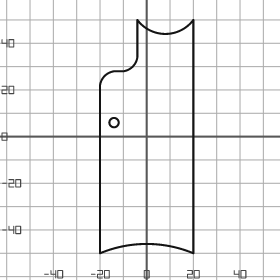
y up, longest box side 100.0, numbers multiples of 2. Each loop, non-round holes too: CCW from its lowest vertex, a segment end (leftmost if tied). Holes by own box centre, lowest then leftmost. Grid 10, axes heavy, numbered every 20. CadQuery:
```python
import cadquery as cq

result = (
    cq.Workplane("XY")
    .moveTo(-20.0, -50.0)
    .threePointArc((0.0, -46.0), (20.0, -50.0))
    .lineTo(20.0, 50.0)
    .threePointArc((8.0, 44.0), (-4.0, 50.0))
    .lineTo(-4.0, 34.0)
    .threePointArc((-6.0, 30.0), (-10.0, 28.0))
    .lineTo(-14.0, 28.0)
    .threePointArc((-18.0, 26.0), (-20.0, 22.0))
    .close()
    .moveTo(-14.0, 6.0)
    .circle(2.0)
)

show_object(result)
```